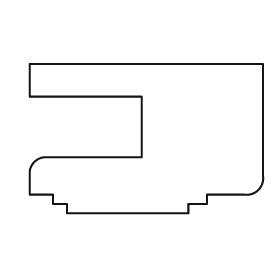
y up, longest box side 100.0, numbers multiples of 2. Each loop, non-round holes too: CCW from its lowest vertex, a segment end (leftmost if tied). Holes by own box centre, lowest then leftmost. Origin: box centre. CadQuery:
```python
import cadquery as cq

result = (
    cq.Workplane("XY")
    .moveTo(-34.0, -32.0)
    .lineTo(18.0, -32.0)
    .lineTo(18.0, -28.0)
    .lineTo(26.0, -28.0)
    .lineTo(26.0, -24.0)
    .lineTo(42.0, -24.0)
    .threePointArc((48.0, -22.0), (50.0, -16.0))
    .lineTo(50.0, 32.0)
    .lineTo(-50.0, 32.0)
    .lineTo(-50.0, 18.0)
    .lineTo(-2.0, 18.0)
    .lineTo(-2.0, -8.0)
    .lineTo(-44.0, -8.0)
    .threePointArc((-48.0, -10.0), (-50.0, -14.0))
    .lineTo(-50.0, -24.0)
    .lineTo(-40.0, -24.0)
    .lineTo(-40.0, -28.0)
    .lineTo(-34.0, -28.0)
    .close()
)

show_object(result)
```